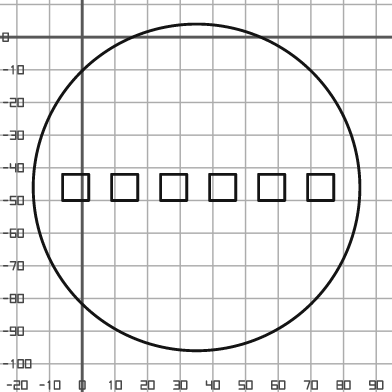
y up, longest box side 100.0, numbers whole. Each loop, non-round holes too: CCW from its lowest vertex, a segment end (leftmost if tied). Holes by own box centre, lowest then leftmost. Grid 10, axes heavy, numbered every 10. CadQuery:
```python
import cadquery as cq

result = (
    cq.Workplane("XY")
    .moveTo(35.0, -46.0)
    .circle(50.0)
    .moveTo(-6.0, -50.0)
    .lineTo(2.0, -50.0)
    .lineTo(2.0, -42.0)
    .lineTo(-6.0, -42.0)
    .close()
    .moveTo(9.0, -50.0)
    .lineTo(17.0, -50.0)
    .lineTo(17.0, -42.0)
    .lineTo(9.0, -42.0)
    .close()
    .moveTo(24.0, -50.0)
    .lineTo(32.0, -50.0)
    .lineTo(32.0, -42.0)
    .lineTo(24.0, -42.0)
    .close()
    .moveTo(39.0, -50.0)
    .lineTo(47.0, -50.0)
    .lineTo(47.0, -42.0)
    .lineTo(39.0, -42.0)
    .close()
    .moveTo(54.0, -50.0)
    .lineTo(62.0, -50.0)
    .lineTo(62.0, -42.0)
    .lineTo(54.0, -42.0)
    .close()
    .moveTo(69.0, -50.0)
    .lineTo(77.0, -50.0)
    .lineTo(77.0, -42.0)
    .lineTo(69.0, -42.0)
    .close()
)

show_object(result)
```